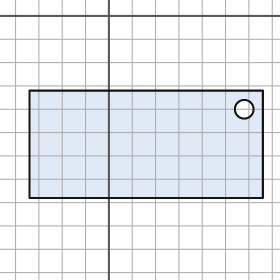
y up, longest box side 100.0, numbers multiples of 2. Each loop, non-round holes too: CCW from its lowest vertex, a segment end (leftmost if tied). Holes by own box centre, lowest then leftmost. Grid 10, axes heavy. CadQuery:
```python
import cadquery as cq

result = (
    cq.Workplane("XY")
    .moveTo(-34.0, -78.0)
    .lineTo(66.0, -78.0)
    .lineTo(66.0, -32.0)
    .lineTo(-34.0, -32.0)
    .close()
    .moveTo(58.0, -40.0)
    .circle(4.0)
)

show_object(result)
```